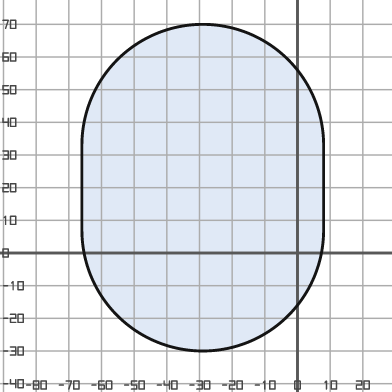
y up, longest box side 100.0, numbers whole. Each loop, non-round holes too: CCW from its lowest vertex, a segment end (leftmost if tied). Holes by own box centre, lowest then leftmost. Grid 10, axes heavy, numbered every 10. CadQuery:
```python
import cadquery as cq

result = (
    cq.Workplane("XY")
    .moveTo(-66.0, 7.0)
    .threePointArc((-29.0, -30.0), (8.0, 7.0))
    .lineTo(8.0, 33.0)
    .threePointArc((-29.0, 70.0), (-66.0, 33.0))
    .close()
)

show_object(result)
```